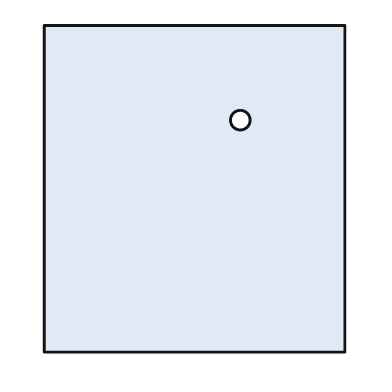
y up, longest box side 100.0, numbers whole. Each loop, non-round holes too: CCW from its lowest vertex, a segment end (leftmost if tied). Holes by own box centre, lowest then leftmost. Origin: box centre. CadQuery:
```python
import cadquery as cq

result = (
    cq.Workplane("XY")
    .moveTo(-46.0, -50.0)
    .lineTo(46.0, -50.0)
    .lineTo(46.0, 50.0)
    .lineTo(-46.0, 50.0)
    .close()
    .moveTo(14.0, 21.0)
    .circle(3.0)
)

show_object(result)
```